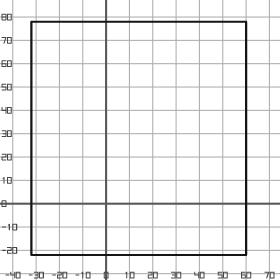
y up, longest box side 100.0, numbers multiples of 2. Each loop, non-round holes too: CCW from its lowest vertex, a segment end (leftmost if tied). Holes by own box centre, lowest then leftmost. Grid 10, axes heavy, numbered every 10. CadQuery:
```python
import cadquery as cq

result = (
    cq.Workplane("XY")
    .moveTo(-32.0, -22.0)
    .lineTo(60.0, -22.0)
    .lineTo(60.0, 78.0)
    .lineTo(-32.0, 78.0)
    .close()
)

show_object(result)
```